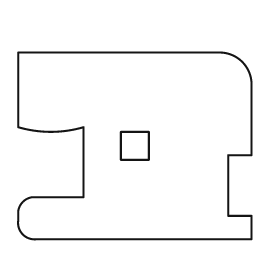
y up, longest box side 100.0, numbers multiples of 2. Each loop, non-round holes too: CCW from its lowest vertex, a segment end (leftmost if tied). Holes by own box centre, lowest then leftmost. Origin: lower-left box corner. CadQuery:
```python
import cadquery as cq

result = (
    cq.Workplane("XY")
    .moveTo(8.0, 0.0)
    .lineTo(100.0, 0.0)
    .lineTo(100.0, 10.0)
    .lineTo(90.0, 10.0)
    .lineTo(90.0, 36.0)
    .lineTo(100.0, 36.0)
    .lineTo(100.0, 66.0)
    .threePointArc((96.0, 76.0), (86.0, 80.0))
    .lineTo(0.0, 80.0)
    .lineTo(0.0, 48.0)
    .threePointArc((14.0, 46.0), (28.0, 48.0))
    .lineTo(28.0, 18.0)
    .lineTo(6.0, 18.0)
    .threePointArc((2.0, 16.0), (0.0, 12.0))
    .lineTo(0.0, 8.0)
    .threePointArc((2.0, 2.0), (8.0, 0.0))
    .close()
    .moveTo(44.0, 34.0)
    .lineTo(56.0, 34.0)
    .lineTo(56.0, 46.0)
    .lineTo(44.0, 46.0)
    .close()
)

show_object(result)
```